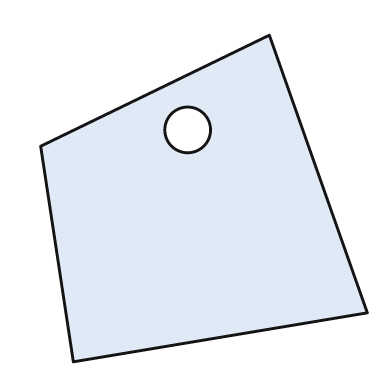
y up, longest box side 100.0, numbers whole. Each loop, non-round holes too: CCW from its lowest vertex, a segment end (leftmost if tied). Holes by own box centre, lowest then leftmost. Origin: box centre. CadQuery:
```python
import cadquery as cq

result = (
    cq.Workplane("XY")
    .moveTo(-40.0, -50.0)
    .lineTo(50.0, -35.0)
    .lineTo(20.0, 50.0)
    .lineTo(-50.0, 16.0)
    .close()
    .moveTo(-5.0, 21.0)
    .circle(7.0)
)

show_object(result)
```